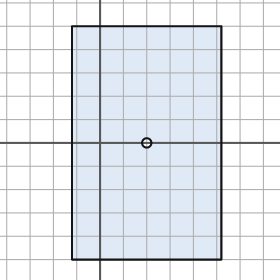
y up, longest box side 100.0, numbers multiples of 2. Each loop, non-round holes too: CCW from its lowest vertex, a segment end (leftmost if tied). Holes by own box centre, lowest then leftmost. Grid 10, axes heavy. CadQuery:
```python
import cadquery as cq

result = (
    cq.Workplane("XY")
    .moveTo(-12.0, -50.0)
    .lineTo(52.0, -50.0)
    .lineTo(52.0, 50.0)
    .lineTo(-12.0, 50.0)
    .close()
    .moveTo(20.0, 0.0)
    .circle(2.0)
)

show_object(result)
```